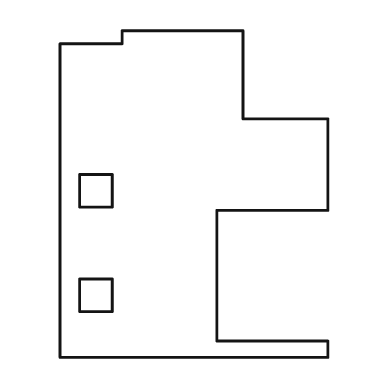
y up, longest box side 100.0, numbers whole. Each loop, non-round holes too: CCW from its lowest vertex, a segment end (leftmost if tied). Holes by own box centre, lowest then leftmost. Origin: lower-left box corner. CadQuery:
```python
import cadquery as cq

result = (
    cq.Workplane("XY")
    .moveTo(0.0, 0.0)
    .lineTo(82.0, 0.0)
    .lineTo(82.0, 5.0)
    .lineTo(48.0, 5.0)
    .lineTo(48.0, 45.0)
    .lineTo(82.0, 45.0)
    .lineTo(82.0, 73.0)
    .lineTo(56.0, 73.0)
    .lineTo(56.0, 100.0)
    .lineTo(19.0, 100.0)
    .lineTo(19.0, 96.0)
    .lineTo(0.0, 96.0)
    .close()
    .moveTo(6.0, 14.0)
    .lineTo(16.0, 14.0)
    .lineTo(16.0, 24.0)
    .lineTo(6.0, 24.0)
    .close()
    .moveTo(6.0, 46.0)
    .lineTo(16.0, 46.0)
    .lineTo(16.0, 56.0)
    .lineTo(6.0, 56.0)
    .close()
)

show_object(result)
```